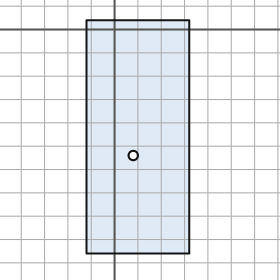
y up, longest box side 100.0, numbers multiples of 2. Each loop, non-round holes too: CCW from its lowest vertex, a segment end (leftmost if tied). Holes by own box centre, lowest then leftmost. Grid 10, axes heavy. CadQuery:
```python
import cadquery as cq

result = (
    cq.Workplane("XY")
    .moveTo(-12.0, -96.0)
    .lineTo(32.0, -96.0)
    .lineTo(32.0, 4.0)
    .lineTo(-12.0, 4.0)
    .close()
    .moveTo(8.0, -54.0)
    .circle(2.0)
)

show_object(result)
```